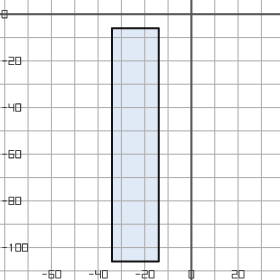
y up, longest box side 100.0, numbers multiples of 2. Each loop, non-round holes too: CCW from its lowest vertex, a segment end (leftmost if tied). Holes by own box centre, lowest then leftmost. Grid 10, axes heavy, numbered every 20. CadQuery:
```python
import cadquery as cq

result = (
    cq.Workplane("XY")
    .moveTo(-34.0, -106.0)
    .lineTo(-14.0, -106.0)
    .lineTo(-14.0, -6.0)
    .lineTo(-34.0, -6.0)
    .close()
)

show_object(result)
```